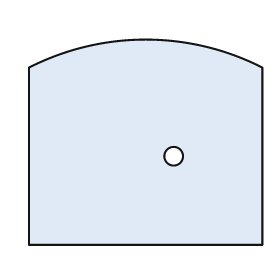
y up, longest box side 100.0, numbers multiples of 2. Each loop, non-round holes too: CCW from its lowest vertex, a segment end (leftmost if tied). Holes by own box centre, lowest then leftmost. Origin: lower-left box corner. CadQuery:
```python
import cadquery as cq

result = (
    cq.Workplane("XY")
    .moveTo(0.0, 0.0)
    .lineTo(100.0, 0.0)
    .lineTo(100.0, 76.0)
    .threePointArc((50.0, 88.0), (0.0, 76.0))
    .close()
    .moveTo(62.0, 38.0)
    .circle(4.0)
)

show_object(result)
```